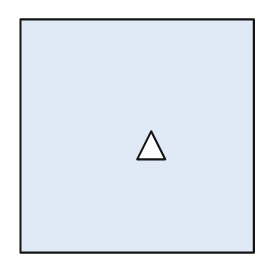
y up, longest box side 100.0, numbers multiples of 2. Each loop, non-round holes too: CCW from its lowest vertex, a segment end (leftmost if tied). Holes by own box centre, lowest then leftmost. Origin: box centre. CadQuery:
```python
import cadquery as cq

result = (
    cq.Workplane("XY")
    .moveTo(-50.0, -50.0)
    .lineTo(50.0, -50.0)
    .lineTo(50.0, 50.0)
    .lineTo(-50.0, 50.0)
    .close()
    .moveTo(0.0, -10.0)
    .lineTo(12.0, -10.0)
    .lineTo(6.0, 2.0)
    .close()
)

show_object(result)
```